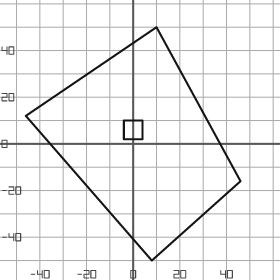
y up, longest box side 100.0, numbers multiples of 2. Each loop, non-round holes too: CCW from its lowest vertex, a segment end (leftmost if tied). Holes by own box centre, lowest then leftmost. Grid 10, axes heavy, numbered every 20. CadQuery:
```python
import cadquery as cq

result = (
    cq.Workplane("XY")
    .moveTo(8.0, -50.0)
    .lineTo(46.0, -16.0)
    .lineTo(10.0, 50.0)
    .lineTo(-46.0, 12.0)
    .close()
    .moveTo(-4.0, 2.0)
    .lineTo(4.0, 2.0)
    .lineTo(4.0, 10.0)
    .lineTo(-4.0, 10.0)
    .close()
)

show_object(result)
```